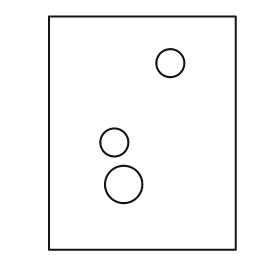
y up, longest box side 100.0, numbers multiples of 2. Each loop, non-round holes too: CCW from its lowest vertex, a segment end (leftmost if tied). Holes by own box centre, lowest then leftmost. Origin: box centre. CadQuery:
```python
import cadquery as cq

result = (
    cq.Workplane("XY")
    .moveTo(-40.0, -50.0)
    .lineTo(40.0, -50.0)
    .lineTo(40.0, 50.0)
    .lineTo(-40.0, 50.0)
    .close()
    .moveTo(-8.0, -22.0)
    .circle(8.0)
    .moveTo(-12.0, -4.0)
    .circle(6.0)
    .moveTo(12.0, 30.0)
    .circle(6.0)
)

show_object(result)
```